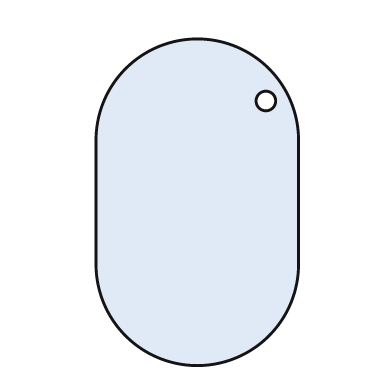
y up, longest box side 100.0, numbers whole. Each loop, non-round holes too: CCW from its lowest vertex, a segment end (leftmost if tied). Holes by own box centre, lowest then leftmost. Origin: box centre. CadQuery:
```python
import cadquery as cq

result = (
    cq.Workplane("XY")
    .moveTo(-31.0, -19.0)
    .threePointArc((0.0, -50.0), (31.0, -19.0))
    .lineTo(31.0, 19.0)
    .threePointArc((0.0, 50.0), (-31.0, 19.0))
    .close()
    .moveTo(21.0, 31.0)
    .circle(3.0)
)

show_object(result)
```